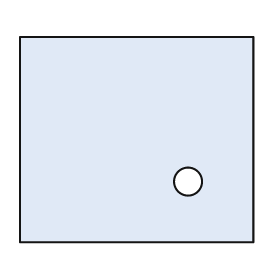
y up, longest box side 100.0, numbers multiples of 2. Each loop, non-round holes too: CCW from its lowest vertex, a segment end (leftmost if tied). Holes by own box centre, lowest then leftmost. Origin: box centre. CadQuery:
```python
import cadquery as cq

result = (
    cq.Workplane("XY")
    .moveTo(-50.0, -44.0)
    .lineTo(50.0, -44.0)
    .lineTo(50.0, 44.0)
    .lineTo(-50.0, 44.0)
    .close()
    .moveTo(22.0, -18.0)
    .circle(6.0)
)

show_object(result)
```